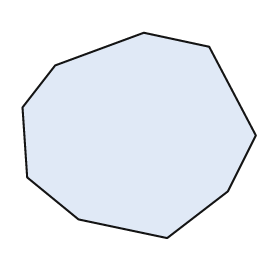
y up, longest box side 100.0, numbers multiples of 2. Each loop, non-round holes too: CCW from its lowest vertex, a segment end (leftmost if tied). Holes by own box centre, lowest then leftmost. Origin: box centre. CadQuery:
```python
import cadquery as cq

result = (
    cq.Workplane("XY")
    .moveTo(12.0, -44.0)
    .lineTo(38.0, -24.0)
    .lineTo(50.0, 0.0)
    .lineTo(30.0, 38.0)
    .lineTo(2.0, 44.0)
    .lineTo(-36.0, 30.0)
    .lineTo(-50.0, 12.0)
    .lineTo(-48.0, -18.0)
    .lineTo(-26.0, -36.0)
    .close()
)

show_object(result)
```